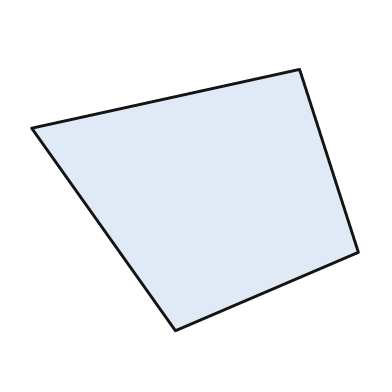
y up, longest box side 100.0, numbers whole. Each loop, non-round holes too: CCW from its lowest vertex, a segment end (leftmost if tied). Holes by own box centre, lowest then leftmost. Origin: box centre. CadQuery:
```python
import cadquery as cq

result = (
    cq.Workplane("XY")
    .moveTo(-6.0, -40.0)
    .lineTo(50.0, -16.0)
    .lineTo(32.0, 40.0)
    .lineTo(-50.0, 22.0)
    .close()
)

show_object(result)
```